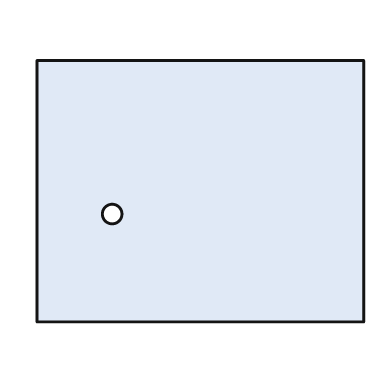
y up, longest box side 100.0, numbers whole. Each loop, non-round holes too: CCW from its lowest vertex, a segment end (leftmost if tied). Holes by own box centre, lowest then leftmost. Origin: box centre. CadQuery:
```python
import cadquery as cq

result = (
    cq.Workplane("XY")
    .moveTo(-50.0, -40.0)
    .lineTo(50.0, -40.0)
    .lineTo(50.0, 40.0)
    .lineTo(-50.0, 40.0)
    .close()
    .moveTo(-27.0, -7.0)
    .circle(3.0)
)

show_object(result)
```